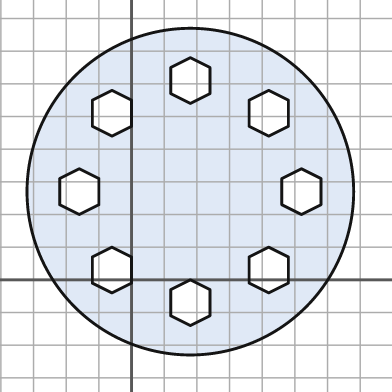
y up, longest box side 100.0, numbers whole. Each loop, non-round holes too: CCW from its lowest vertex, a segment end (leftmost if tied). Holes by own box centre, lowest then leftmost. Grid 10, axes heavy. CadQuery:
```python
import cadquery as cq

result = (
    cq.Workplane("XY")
    .moveTo(18.0, 27.0)
    .circle(50.0)
    .moveTo(18.0, -14.0)
    .lineTo(24.0, -11.0)
    .lineTo(24.0, -3.0)
    .lineTo(18.0, 0.0)
    .lineTo(12.0, -3.0)
    .lineTo(12.0, -11.0)
    .close()
    .moveTo(-6.0, -4.0)
    .lineTo(0.0, -1.0)
    .lineTo(0.0, 7.0)
    .lineTo(-6.0, 10.0)
    .lineTo(-12.0, 7.0)
    .lineTo(-12.0, -1.0)
    .close()
    .moveTo(42.0, -4.0)
    .lineTo(48.0, -1.0)
    .lineTo(48.0, 7.0)
    .lineTo(42.0, 10.0)
    .lineTo(36.0, 7.0)
    .lineTo(36.0, -1.0)
    .close()
    .moveTo(-16.0, 20.0)
    .lineTo(-10.0, 23.0)
    .lineTo(-10.0, 31.0)
    .lineTo(-16.0, 34.0)
    .lineTo(-22.0, 31.0)
    .lineTo(-22.0, 23.0)
    .close()
    .moveTo(52.0, 20.0)
    .lineTo(58.0, 23.0)
    .lineTo(58.0, 31.0)
    .lineTo(52.0, 34.0)
    .lineTo(46.0, 31.0)
    .lineTo(46.0, 23.0)
    .close()
    .moveTo(-6.0, 44.0)
    .lineTo(0.0, 47.0)
    .lineTo(0.0, 55.0)
    .lineTo(-6.0, 58.0)
    .lineTo(-12.0, 55.0)
    .lineTo(-12.0, 47.0)
    .close()
    .moveTo(42.0, 44.0)
    .lineTo(48.0, 47.0)
    .lineTo(48.0, 55.0)
    .lineTo(42.0, 58.0)
    .lineTo(36.0, 55.0)
    .lineTo(36.0, 47.0)
    .close()
    .moveTo(18.0, 54.0)
    .lineTo(24.0, 57.0)
    .lineTo(24.0, 65.0)
    .lineTo(18.0, 68.0)
    .lineTo(12.0, 65.0)
    .lineTo(12.0, 57.0)
    .close()
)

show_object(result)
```